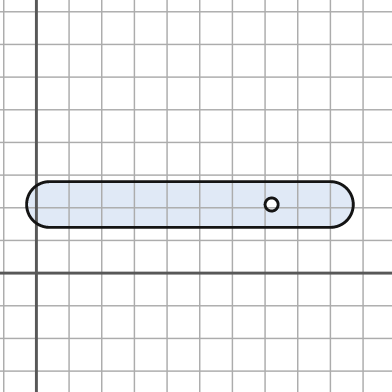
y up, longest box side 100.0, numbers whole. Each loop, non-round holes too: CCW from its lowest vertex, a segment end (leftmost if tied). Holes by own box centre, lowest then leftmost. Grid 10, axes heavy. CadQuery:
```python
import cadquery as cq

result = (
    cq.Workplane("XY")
    .moveTo(4.0, 14.0)
    .lineTo(90.0, 14.0)
    .threePointArc((97.0, 21.0), (90.0, 28.0))
    .lineTo(4.0, 28.0)
    .threePointArc((-3.0, 21.0), (4.0, 14.0))
    .close()
    .moveTo(72.0, 21.0)
    .circle(2.0)
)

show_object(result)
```